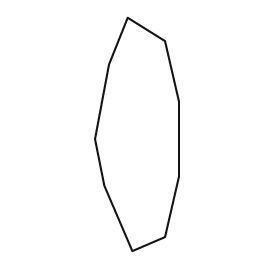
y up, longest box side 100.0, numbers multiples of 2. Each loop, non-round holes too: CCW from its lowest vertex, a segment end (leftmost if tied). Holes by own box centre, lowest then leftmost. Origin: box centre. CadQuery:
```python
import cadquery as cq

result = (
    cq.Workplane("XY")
    .moveTo(-2.0, -50.0)
    .lineTo(12.0, -44.0)
    .lineTo(18.0, -18.0)
    .lineTo(18.0, 14.0)
    .lineTo(12.0, 40.0)
    .lineTo(-4.0, 50.0)
    .lineTo(-12.0, 30.0)
    .lineTo(-18.0, -2.0)
    .lineTo(-14.0, -22.0)
    .close()
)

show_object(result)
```